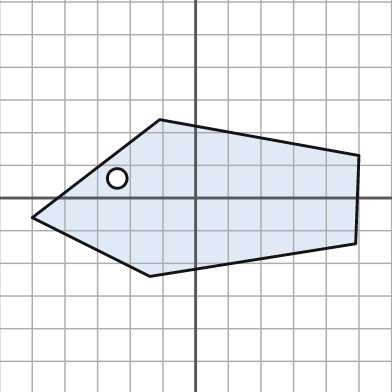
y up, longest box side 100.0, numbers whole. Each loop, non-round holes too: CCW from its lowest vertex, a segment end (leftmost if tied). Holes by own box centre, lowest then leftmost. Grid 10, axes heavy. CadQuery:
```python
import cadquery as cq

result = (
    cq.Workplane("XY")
    .moveTo(-14.0, -24.0)
    .lineTo(49.0, -14.0)
    .lineTo(50.0, 13.0)
    .lineTo(-11.0, 24.0)
    .lineTo(-50.0, -6.0)
    .close()
    .moveTo(-24.0, 6.0)
    .circle(3.0)
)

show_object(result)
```